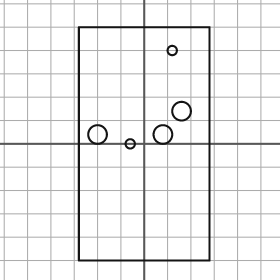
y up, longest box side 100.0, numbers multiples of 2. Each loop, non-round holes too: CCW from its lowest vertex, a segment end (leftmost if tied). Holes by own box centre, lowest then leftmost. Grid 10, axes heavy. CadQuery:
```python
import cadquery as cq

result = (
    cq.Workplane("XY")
    .moveTo(-28.0, -50.0)
    .lineTo(28.0, -50.0)
    .lineTo(28.0, 50.0)
    .lineTo(-28.0, 50.0)
    .close()
    .moveTo(-6.0, 0.0)
    .circle(2.0)
    .moveTo(-20.0, 4.0)
    .circle(4.0)
    .moveTo(8.0, 4.0)
    .circle(4.0)
    .moveTo(16.0, 14.0)
    .circle(4.0)
    .moveTo(12.0, 40.0)
    .circle(2.0)
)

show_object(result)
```